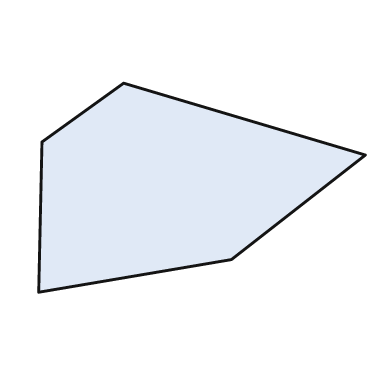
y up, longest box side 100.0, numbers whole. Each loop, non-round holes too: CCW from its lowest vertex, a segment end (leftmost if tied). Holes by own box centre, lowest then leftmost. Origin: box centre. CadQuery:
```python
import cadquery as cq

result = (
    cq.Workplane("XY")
    .moveTo(-50.0, -32.0)
    .lineTo(9.0, -22.0)
    .lineTo(50.0, 10.0)
    .lineTo(-24.0, 32.0)
    .lineTo(-49.0, 14.0)
    .close()
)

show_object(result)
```